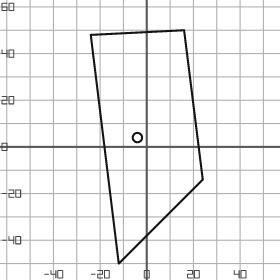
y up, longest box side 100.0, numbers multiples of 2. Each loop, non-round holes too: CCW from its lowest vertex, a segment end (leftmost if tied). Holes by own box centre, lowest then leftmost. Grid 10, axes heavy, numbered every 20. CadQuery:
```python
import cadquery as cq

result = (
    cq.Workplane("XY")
    .moveTo(-12.0, -50.0)
    .lineTo(24.0, -14.0)
    .lineTo(16.0, 50.0)
    .lineTo(-24.0, 48.0)
    .close()
    .moveTo(-4.0, 4.0)
    .circle(2.0)
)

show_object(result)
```